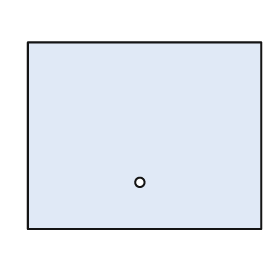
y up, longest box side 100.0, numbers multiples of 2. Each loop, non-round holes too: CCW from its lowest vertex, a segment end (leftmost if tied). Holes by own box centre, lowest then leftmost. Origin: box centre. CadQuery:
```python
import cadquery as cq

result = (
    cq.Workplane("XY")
    .moveTo(-50.0, -40.0)
    .lineTo(50.0, -40.0)
    .lineTo(50.0, 40.0)
    .lineTo(-50.0, 40.0)
    .close()
    .moveTo(-2.0, -20.0)
    .circle(2.0)
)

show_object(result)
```